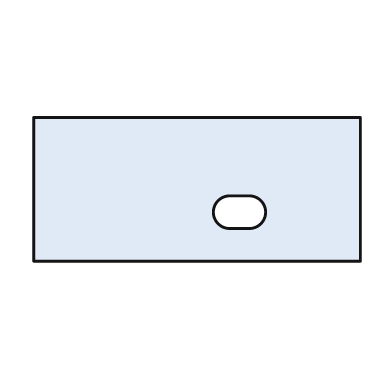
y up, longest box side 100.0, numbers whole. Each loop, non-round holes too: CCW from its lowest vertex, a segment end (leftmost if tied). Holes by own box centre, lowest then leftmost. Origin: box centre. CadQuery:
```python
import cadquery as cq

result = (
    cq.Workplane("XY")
    .moveTo(-50.0, -22.0)
    .lineTo(50.0, -22.0)
    .lineTo(50.0, 22.0)
    .lineTo(-50.0, 22.0)
    .close()
    .moveTo(10.0, -12.0)
    .lineTo(16.0, -12.0)
    .threePointArc((21.0, -7.0), (16.0, -2.0))
    .lineTo(10.0, -2.0)
    .threePointArc((5.0, -7.0), (10.0, -12.0))
    .close()
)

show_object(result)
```